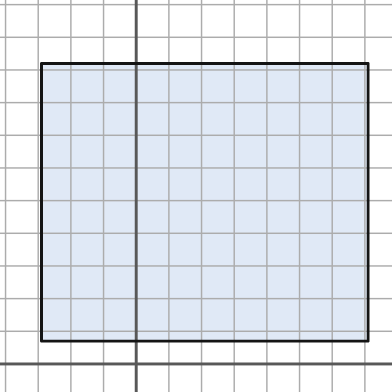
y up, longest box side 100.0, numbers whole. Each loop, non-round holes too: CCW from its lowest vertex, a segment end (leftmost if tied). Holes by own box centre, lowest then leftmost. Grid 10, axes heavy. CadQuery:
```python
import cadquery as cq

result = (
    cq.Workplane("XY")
    .moveTo(-29.0, 7.0)
    .lineTo(71.0, 7.0)
    .lineTo(71.0, 92.0)
    .lineTo(-29.0, 92.0)
    .close()
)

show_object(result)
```